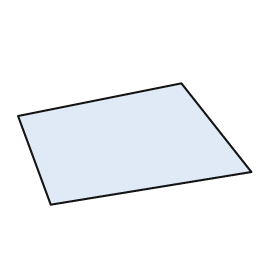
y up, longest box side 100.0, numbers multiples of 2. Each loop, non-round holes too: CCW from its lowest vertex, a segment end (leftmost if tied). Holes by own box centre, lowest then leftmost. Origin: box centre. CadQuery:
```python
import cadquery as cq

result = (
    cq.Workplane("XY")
    .moveTo(-36.0, -26.0)
    .lineTo(50.0, -12.0)
    .lineTo(20.0, 26.0)
    .lineTo(-50.0, 12.0)
    .close()
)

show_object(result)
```